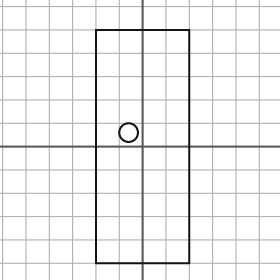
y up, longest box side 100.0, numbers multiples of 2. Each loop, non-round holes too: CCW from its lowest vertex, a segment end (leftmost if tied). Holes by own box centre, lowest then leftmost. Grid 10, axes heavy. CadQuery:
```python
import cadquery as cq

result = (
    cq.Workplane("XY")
    .moveTo(-20.0, -50.0)
    .lineTo(20.0, -50.0)
    .lineTo(20.0, 50.0)
    .lineTo(-20.0, 50.0)
    .close()
    .moveTo(-6.0, 6.0)
    .circle(4.0)
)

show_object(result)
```